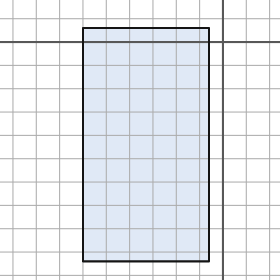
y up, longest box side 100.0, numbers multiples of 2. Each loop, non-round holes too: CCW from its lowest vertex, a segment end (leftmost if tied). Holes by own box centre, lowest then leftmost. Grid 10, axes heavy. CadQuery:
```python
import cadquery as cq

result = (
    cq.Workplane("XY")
    .moveTo(-60.0, -94.0)
    .lineTo(-6.0, -94.0)
    .lineTo(-6.0, 6.0)
    .lineTo(-60.0, 6.0)
    .close()
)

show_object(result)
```